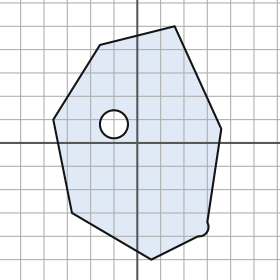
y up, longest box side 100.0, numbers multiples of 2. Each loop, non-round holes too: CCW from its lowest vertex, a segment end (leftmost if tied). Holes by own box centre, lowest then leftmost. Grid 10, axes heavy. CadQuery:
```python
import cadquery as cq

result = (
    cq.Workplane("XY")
    .moveTo(6.0, -50.0)
    .lineTo(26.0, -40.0)
    .threePointArc((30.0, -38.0), (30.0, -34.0))
    .lineTo(36.0, 6.0)
    .lineTo(16.0, 50.0)
    .lineTo(-16.0, 42.0)
    .lineTo(-36.0, 10.0)
    .lineTo(-28.0, -30.0)
    .close()
    .moveTo(-10.0, 8.0)
    .circle(6.0)
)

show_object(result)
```